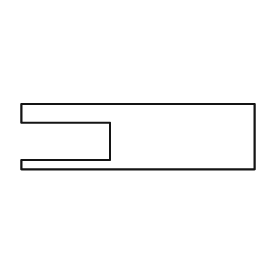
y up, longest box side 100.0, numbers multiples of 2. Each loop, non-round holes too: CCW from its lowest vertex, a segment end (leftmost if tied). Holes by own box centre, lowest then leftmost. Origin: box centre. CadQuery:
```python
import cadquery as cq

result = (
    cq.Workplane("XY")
    .moveTo(-50.0, -14.0)
    .lineTo(50.0, -14.0)
    .lineTo(50.0, 14.0)
    .lineTo(-50.0, 14.0)
    .lineTo(-50.0, 6.0)
    .lineTo(-12.0, 6.0)
    .lineTo(-12.0, -10.0)
    .lineTo(-50.0, -10.0)
    .close()
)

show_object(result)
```